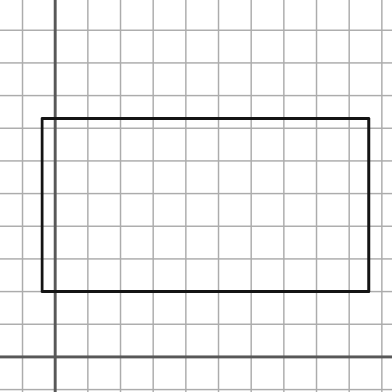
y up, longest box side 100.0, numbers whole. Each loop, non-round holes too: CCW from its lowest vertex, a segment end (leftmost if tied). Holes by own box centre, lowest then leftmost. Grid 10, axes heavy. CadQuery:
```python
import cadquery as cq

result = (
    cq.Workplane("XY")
    .moveTo(-4.0, 20.0)
    .lineTo(96.0, 20.0)
    .lineTo(96.0, 73.0)
    .lineTo(-4.0, 73.0)
    .close()
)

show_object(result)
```